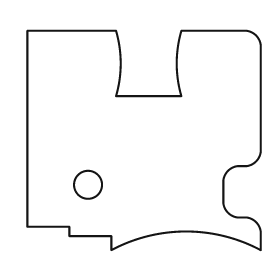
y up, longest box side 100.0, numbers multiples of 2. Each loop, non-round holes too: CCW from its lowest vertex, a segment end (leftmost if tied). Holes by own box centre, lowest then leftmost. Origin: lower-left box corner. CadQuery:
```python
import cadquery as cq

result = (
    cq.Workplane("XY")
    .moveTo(36.0, 0.0)
    .threePointArc((68.0, 8.0), (100.0, 0.0))
    .lineTo(100.0, 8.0)
    .threePointArc((98.0, 12.0), (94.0, 14.0))
    .lineTo(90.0, 14.0)
    .threePointArc((86.0, 16.0), (84.0, 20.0))
    .lineTo(84.0, 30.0)
    .threePointArc((86.0, 34.0), (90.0, 36.0))
    .lineTo(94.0, 36.0)
    .threePointArc((98.0, 38.0), (100.0, 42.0))
    .lineTo(100.0, 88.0)
    .threePointArc((98.0, 92.0), (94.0, 94.0))
    .lineTo(66.0, 94.0)
    .threePointArc((64.0, 80.0), (66.0, 66.0))
    .lineTo(38.0, 66.0)
    .threePointArc((40.0, 80.0), (38.0, 94.0))
    .lineTo(0.0, 94.0)
    .lineTo(0.0, 10.0)
    .lineTo(18.0, 10.0)
    .lineTo(18.0, 6.0)
    .lineTo(36.0, 6.0)
    .close()
    .moveTo(26.0, 28.0)
    .circle(6.0)
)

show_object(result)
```